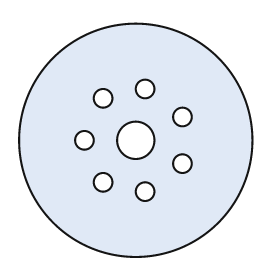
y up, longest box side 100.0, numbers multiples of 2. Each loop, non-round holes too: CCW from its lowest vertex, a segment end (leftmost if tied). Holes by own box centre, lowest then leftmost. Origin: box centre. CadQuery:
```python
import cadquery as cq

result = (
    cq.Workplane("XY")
    .moveTo(0.0, 0.0)
    .circle(50.0)
    .moveTo(4.0, -22.0)
    .circle(4.0)
    .moveTo(-14.0, -18.0)
    .circle(4.0)
    .moveTo(20.0, -10.0)
    .circle(4.0)
    .moveTo(-22.0, 0.0)
    .circle(4.0)
    .moveTo(0.0, 0.0)
    .circle(8.0)
    .moveTo(20.0, 10.0)
    .circle(4.0)
    .moveTo(-14.0, 18.0)
    .circle(4.0)
    .moveTo(4.0, 22.0)
    .circle(4.0)
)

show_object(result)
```